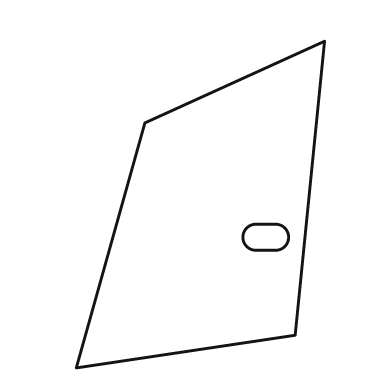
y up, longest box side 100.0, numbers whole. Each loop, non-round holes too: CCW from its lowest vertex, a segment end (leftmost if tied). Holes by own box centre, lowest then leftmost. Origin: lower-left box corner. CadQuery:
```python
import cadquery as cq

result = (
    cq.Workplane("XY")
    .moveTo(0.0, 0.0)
    .lineTo(67.0, 10.0)
    .lineTo(76.0, 100.0)
    .lineTo(21.0, 75.0)
    .close()
    .moveTo(55.0, 36.0)
    .lineTo(61.0, 36.0)
    .threePointArc((65.0, 40.0), (61.0, 44.0))
    .lineTo(55.0, 44.0)
    .threePointArc((51.0, 40.0), (55.0, 36.0))
    .close()
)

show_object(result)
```